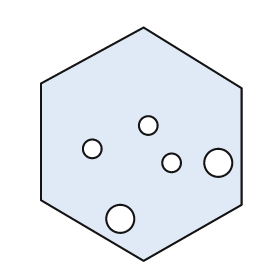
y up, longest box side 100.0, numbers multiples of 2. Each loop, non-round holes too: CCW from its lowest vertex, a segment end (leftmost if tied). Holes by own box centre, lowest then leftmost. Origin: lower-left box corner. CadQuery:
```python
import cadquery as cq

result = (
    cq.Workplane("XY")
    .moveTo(44.0, 0.0)
    .lineTo(86.0, 24.0)
    .lineTo(86.0, 74.0)
    .lineTo(44.0, 100.0)
    .lineTo(0.0, 76.0)
    .lineTo(0.0, 26.0)
    .close()
    .moveTo(34.0, 18.0)
    .circle(6.0)
    .moveTo(56.0, 42.0)
    .circle(4.0)
    .moveTo(76.0, 42.0)
    .circle(6.0)
    .moveTo(22.0, 48.0)
    .circle(4.0)
    .moveTo(46.0, 58.0)
    .circle(4.0)
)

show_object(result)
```